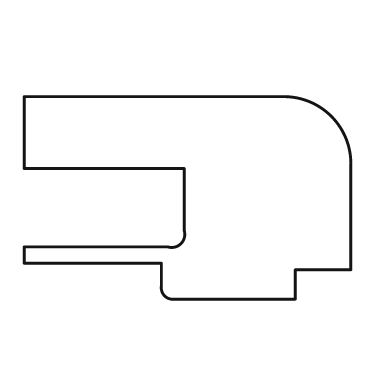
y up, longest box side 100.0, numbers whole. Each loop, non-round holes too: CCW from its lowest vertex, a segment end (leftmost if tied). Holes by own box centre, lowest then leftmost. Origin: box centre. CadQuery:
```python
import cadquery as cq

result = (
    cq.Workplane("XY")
    .moveTo(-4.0, -31.0)
    .lineTo(33.0, -31.0)
    .lineTo(33.0, -22.0)
    .lineTo(50.0, -22.0)
    .lineTo(50.0, 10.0)
    .threePointArc((44.0, 25.0), (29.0, 31.0))
    .lineTo(-50.0, 31.0)
    .lineTo(-50.0, 9.0)
    .lineTo(-1.0, 9.0)
    .lineTo(-1.0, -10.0)
    .threePointArc((-2.0, -14.0), (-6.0, -15.0))
    .lineTo(-50.0, -15.0)
    .lineTo(-50.0, -20.0)
    .lineTo(-8.0, -20.0)
    .lineTo(-8.0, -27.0)
    .threePointArc((-7.0, -30.0), (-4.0, -31.0))
    .close()
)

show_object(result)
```